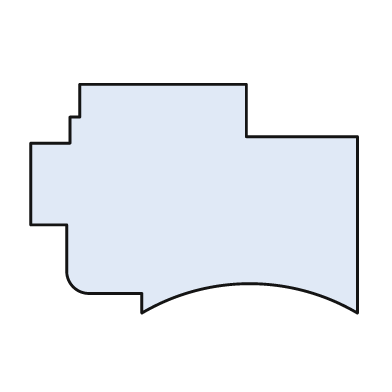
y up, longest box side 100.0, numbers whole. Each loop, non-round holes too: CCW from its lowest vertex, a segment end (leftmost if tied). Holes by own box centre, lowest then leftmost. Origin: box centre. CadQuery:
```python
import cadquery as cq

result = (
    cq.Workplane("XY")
    .moveTo(-16.0, -35.0)
    .threePointArc((17.0, -26.0), (50.0, -35.0))
    .lineTo(50.0, 19.0)
    .lineTo(16.0, 19.0)
    .lineTo(16.0, 35.0)
    .lineTo(-35.0, 35.0)
    .lineTo(-35.0, 25.0)
    .lineTo(-38.0, 25.0)
    .lineTo(-38.0, 17.0)
    .lineTo(-50.0, 17.0)
    .lineTo(-50.0, -8.0)
    .lineTo(-39.0, -8.0)
    .lineTo(-39.0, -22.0)
    .threePointArc((-37.0, -27.0), (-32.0, -29.0))
    .lineTo(-16.0, -29.0)
    .close()
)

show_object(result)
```